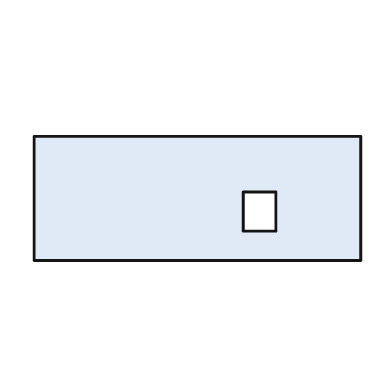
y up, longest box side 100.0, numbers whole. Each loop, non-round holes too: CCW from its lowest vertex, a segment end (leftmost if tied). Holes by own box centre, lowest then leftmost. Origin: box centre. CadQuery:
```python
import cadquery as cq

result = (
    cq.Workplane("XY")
    .moveTo(-50.0, -19.0)
    .lineTo(50.0, -19.0)
    .lineTo(50.0, 19.0)
    .lineTo(-50.0, 19.0)
    .close()
    .moveTo(14.0, -10.0)
    .lineTo(24.0, -10.0)
    .lineTo(24.0, 2.0)
    .lineTo(14.0, 2.0)
    .close()
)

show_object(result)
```